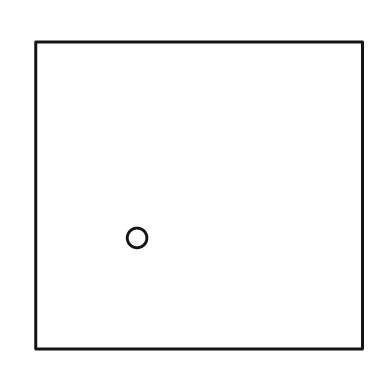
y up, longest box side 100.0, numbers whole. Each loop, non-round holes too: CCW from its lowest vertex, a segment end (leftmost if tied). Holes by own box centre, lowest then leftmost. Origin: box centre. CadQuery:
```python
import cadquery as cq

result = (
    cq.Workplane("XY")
    .moveTo(-50.0, -47.0)
    .lineTo(50.0, -47.0)
    .lineTo(50.0, 47.0)
    .lineTo(-50.0, 47.0)
    .close()
    .moveTo(-19.0, -13.0)
    .circle(3.0)
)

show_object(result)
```